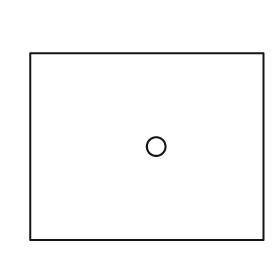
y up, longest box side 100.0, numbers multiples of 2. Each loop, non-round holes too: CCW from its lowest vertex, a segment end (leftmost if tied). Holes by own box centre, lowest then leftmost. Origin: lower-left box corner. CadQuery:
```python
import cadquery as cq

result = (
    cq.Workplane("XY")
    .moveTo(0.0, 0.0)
    .lineTo(100.0, 0.0)
    .lineTo(100.0, 80.0)
    .lineTo(0.0, 80.0)
    .close()
    .moveTo(54.0, 40.0)
    .circle(4.0)
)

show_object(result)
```